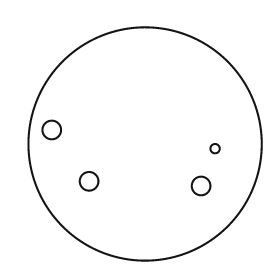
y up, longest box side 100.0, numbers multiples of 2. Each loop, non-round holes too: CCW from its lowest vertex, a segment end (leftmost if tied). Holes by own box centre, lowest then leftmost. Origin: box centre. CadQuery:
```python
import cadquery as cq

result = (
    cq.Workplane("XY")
    .moveTo(0.0, 0.0)
    .circle(50.0)
    .moveTo(24.0, -18.0)
    .circle(4.0)
    .moveTo(-24.0, -16.0)
    .circle(4.0)
    .moveTo(30.0, -2.0)
    .circle(2.0)
    .moveTo(-40.0, 6.0)
    .circle(4.0)
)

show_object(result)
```